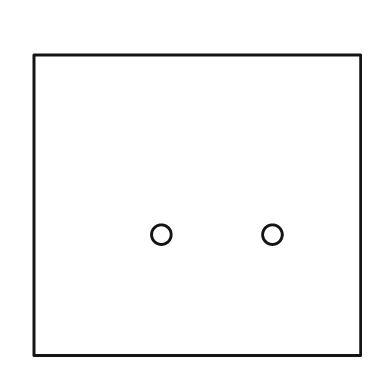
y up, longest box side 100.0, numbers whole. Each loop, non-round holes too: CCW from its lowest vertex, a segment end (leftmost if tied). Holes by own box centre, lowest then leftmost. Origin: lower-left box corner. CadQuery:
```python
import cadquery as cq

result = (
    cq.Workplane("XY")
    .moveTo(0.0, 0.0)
    .lineTo(100.0, 0.0)
    .lineTo(100.0, 92.0)
    .lineTo(0.0, 92.0)
    .close()
    .moveTo(39.0, 37.0)
    .circle(3.0)
    .moveTo(73.0, 37.0)
    .circle(3.0)
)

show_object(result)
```